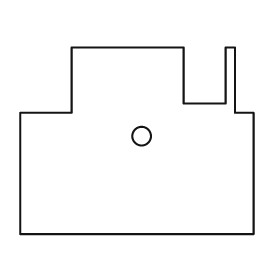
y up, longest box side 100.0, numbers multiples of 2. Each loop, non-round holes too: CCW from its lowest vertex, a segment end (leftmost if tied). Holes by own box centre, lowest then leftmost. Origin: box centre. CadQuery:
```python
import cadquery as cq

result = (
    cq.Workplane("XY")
    .moveTo(-50.0, -40.0)
    .lineTo(50.0, -40.0)
    .lineTo(50.0, 12.0)
    .lineTo(42.0, 12.0)
    .lineTo(42.0, 40.0)
    .lineTo(38.0, 40.0)
    .lineTo(38.0, 16.0)
    .lineTo(20.0, 16.0)
    .lineTo(20.0, 40.0)
    .lineTo(-28.0, 40.0)
    .lineTo(-28.0, 12.0)
    .lineTo(-50.0, 12.0)
    .close()
    .moveTo(2.0, 2.0)
    .circle(4.0)
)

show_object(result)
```